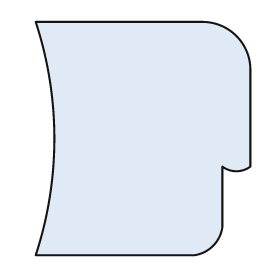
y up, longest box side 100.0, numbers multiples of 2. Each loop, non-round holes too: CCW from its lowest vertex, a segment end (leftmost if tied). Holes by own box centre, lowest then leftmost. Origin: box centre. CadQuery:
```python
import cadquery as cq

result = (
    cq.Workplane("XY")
    .moveTo(-46.0, -50.0)
    .lineTo(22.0, -50.0)
    .threePointArc((30.0, -46.0), (34.0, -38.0))
    .lineTo(34.0, -12.0)
    .threePointArc((40.0, -14.0), (46.0, -12.0))
    .lineTo(46.0, 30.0)
    .threePointArc((40.0, 44.0), (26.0, 50.0))
    .lineTo(-46.0, 50.0)
    .threePointArc((-38.0, 0.0), (-46.0, -50.0))
    .close()
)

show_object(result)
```